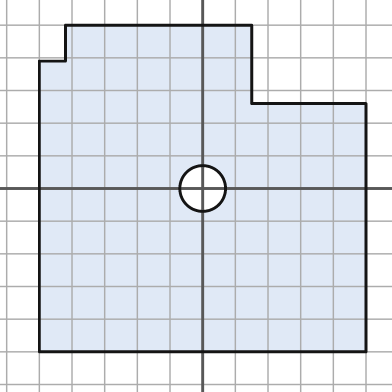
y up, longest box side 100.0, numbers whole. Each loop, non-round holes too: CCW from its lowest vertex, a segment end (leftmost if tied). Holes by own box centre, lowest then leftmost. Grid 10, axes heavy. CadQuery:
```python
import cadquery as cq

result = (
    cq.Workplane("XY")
    .moveTo(-50.0, -50.0)
    .lineTo(50.0, -50.0)
    .lineTo(50.0, 26.0)
    .lineTo(15.0, 26.0)
    .lineTo(15.0, 50.0)
    .lineTo(-42.0, 50.0)
    .lineTo(-42.0, 39.0)
    .lineTo(-50.0, 39.0)
    .close()
    .moveTo(0.0, 0.0)
    .circle(7.0)
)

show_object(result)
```